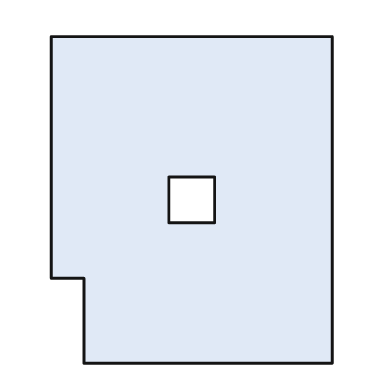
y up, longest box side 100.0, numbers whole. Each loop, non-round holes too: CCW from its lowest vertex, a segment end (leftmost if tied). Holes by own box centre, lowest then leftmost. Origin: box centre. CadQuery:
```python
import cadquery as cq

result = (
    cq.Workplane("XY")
    .moveTo(-33.0, -50.0)
    .lineTo(43.0, -50.0)
    .lineTo(43.0, 50.0)
    .lineTo(-43.0, 50.0)
    .lineTo(-43.0, -24.0)
    .lineTo(-33.0, -24.0)
    .close()
    .moveTo(-7.0, -7.0)
    .lineTo(7.0, -7.0)
    .lineTo(7.0, 7.0)
    .lineTo(-7.0, 7.0)
    .close()
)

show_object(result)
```